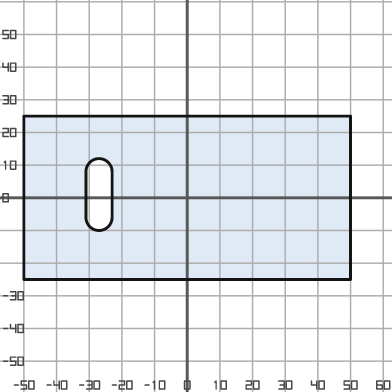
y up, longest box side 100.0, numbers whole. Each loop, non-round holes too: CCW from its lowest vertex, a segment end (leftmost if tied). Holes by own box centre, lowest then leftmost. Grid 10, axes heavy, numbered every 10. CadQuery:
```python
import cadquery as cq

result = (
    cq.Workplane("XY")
    .moveTo(-50.0, -25.0)
    .lineTo(50.0, -25.0)
    .lineTo(50.0, 25.0)
    .lineTo(-50.0, 25.0)
    .close()
    .moveTo(-31.0, -6.0)
    .threePointArc((-27.0, -10.0), (-23.0, -6.0))
    .lineTo(-23.0, 8.0)
    .threePointArc((-27.0, 12.0), (-31.0, 8.0))
    .close()
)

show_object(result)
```